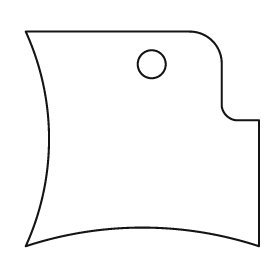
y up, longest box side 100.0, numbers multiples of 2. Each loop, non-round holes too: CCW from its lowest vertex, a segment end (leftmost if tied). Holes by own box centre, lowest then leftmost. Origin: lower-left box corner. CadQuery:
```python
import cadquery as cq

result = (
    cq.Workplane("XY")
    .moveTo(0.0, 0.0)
    .threePointArc((50.0, 8.0), (100.0, 0.0))
    .lineTo(100.0, 54.0)
    .lineTo(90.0, 54.0)
    .threePointArc((86.0, 56.0), (84.0, 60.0))
    .lineTo(84.0, 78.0)
    .threePointArc((80.0, 88.0), (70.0, 92.0))
    .lineTo(0.0, 92.0)
    .threePointArc((10.0, 46.0), (0.0, 0.0))
    .close()
    .moveTo(54.0, 78.0)
    .circle(6.0)
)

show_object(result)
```